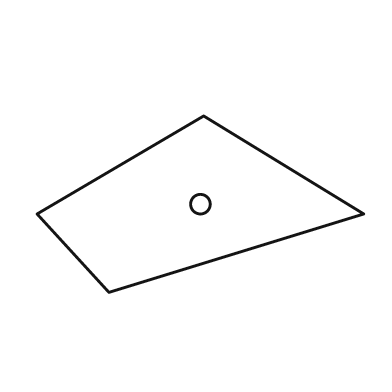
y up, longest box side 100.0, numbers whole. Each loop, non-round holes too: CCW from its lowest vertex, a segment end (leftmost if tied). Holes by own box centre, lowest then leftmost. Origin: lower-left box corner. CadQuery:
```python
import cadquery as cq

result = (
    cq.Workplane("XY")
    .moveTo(22.0, 0.0)
    .lineTo(100.0, 24.0)
    .lineTo(51.0, 54.0)
    .lineTo(0.0, 24.0)
    .close()
    .moveTo(50.0, 27.0)
    .circle(3.0)
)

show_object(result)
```